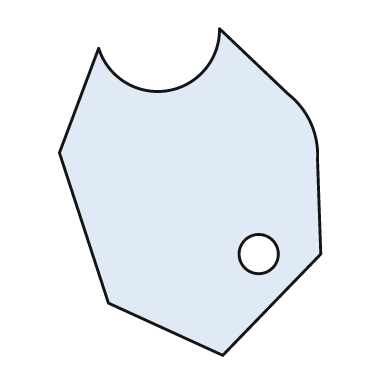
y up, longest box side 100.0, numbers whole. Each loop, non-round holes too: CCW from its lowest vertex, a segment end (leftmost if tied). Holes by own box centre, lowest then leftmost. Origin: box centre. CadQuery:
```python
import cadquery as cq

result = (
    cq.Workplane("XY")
    .moveTo(10.0, -50.0)
    .lineTo(40.0, -19.0)
    .lineTo(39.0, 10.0)
    .threePointArc((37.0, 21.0), (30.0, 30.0))
    .lineTo(9.0, 50.0)
    .threePointArc((-7.0, 31.0), (-28.0, 44.0))
    .lineTo(-40.0, 12.0)
    .lineTo(-25.0, -34.0)
    .close()
    .moveTo(21.0, -19.0)
    .circle(6.0)
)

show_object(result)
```